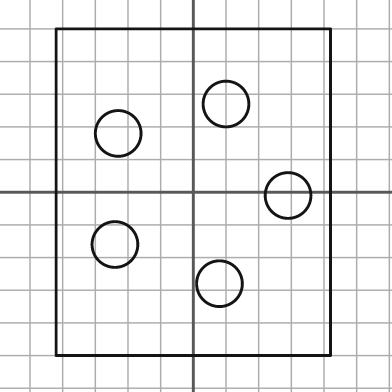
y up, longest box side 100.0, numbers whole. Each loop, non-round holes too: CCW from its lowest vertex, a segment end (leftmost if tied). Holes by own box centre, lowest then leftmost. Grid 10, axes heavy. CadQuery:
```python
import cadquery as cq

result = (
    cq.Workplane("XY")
    .moveTo(-42.0, -50.0)
    .lineTo(42.0, -50.0)
    .lineTo(42.0, 50.0)
    .lineTo(-42.0, 50.0)
    .close()
    .moveTo(8.0, -28.0)
    .circle(7.0)
    .moveTo(-24.0, -16.0)
    .circle(7.0)
    .moveTo(29.0, -1.0)
    .circle(7.0)
    .moveTo(-23.0, 18.0)
    .circle(7.0)
    .moveTo(10.0, 27.0)
    .circle(7.0)
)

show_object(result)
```